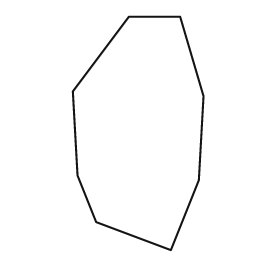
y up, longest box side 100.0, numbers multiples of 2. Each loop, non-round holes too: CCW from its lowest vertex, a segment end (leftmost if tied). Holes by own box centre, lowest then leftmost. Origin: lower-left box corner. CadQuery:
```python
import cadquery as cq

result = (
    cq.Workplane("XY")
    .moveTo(42.0, 0.0)
    .lineTo(54.0, 30.0)
    .lineTo(56.0, 66.0)
    .lineTo(46.0, 100.0)
    .lineTo(24.0, 100.0)
    .lineTo(0.0, 68.0)
    .lineTo(2.0, 32.0)
    .lineTo(10.0, 12.0)
    .close()
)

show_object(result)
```